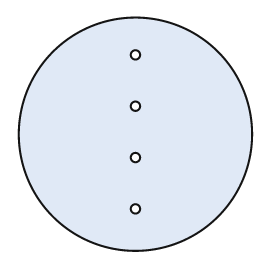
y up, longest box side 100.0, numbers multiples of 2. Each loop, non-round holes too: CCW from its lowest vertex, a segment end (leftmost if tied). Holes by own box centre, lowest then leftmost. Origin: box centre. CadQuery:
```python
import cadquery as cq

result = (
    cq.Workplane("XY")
    .moveTo(0.0, 0.0)
    .circle(50.0)
    .moveTo(0.0, -32.0)
    .circle(2.0)
    .moveTo(0.0, -10.0)
    .circle(2.0)
    .moveTo(0.0, 12.0)
    .circle(2.0)
    .moveTo(0.0, 34.0)
    .circle(2.0)
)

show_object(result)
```